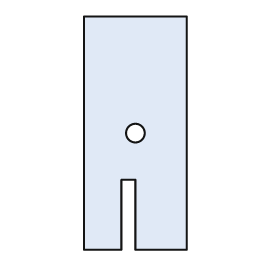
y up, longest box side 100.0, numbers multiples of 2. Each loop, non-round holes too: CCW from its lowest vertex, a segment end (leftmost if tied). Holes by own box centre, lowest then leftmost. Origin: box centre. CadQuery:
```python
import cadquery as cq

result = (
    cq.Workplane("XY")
    .moveTo(-22.0, -50.0)
    .lineTo(-6.0, -50.0)
    .lineTo(-6.0, -20.0)
    .lineTo(0.0, -20.0)
    .lineTo(0.0, -50.0)
    .lineTo(22.0, -50.0)
    .lineTo(22.0, 50.0)
    .lineTo(-22.0, 50.0)
    .close()
    .moveTo(0.0, 0.0)
    .circle(4.0)
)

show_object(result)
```